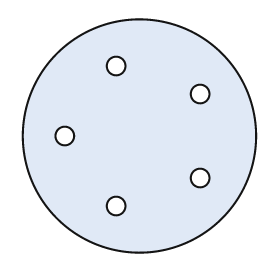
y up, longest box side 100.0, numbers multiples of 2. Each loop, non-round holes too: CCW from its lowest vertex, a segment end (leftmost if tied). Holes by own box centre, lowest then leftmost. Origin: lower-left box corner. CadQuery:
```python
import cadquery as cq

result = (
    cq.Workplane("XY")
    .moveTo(50.0, 50.0)
    .circle(50.0)
    .moveTo(40.0, 20.0)
    .circle(4.0)
    .moveTo(76.0, 32.0)
    .circle(4.0)
    .moveTo(18.0, 50.0)
    .circle(4.0)
    .moveTo(76.0, 68.0)
    .circle(4.0)
    .moveTo(40.0, 80.0)
    .circle(4.0)
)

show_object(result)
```